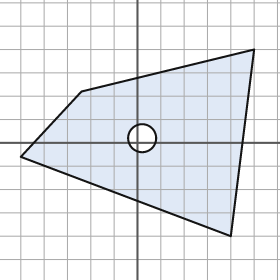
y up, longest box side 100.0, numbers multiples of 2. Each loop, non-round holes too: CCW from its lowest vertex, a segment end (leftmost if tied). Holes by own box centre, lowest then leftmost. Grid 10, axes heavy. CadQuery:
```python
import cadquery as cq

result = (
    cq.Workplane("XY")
    .moveTo(40.0, -40.0)
    .lineTo(50.0, 40.0)
    .lineTo(-24.0, 22.0)
    .lineTo(-50.0, -6.0)
    .close()
    .moveTo(2.0, 2.0)
    .circle(6.0)
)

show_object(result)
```